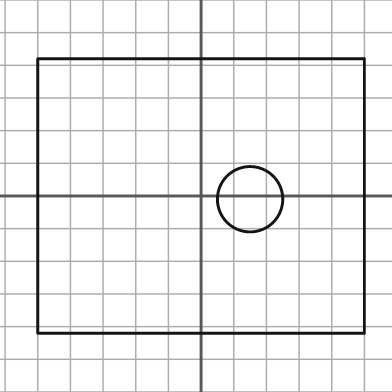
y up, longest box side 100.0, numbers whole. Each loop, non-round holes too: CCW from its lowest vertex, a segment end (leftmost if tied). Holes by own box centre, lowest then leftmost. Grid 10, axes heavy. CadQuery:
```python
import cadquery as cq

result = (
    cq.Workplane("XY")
    .moveTo(-50.0, -42.0)
    .lineTo(50.0, -42.0)
    .lineTo(50.0, 42.0)
    .lineTo(-50.0, 42.0)
    .close()
    .moveTo(15.0, -1.0)
    .circle(10.0)
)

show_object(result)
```